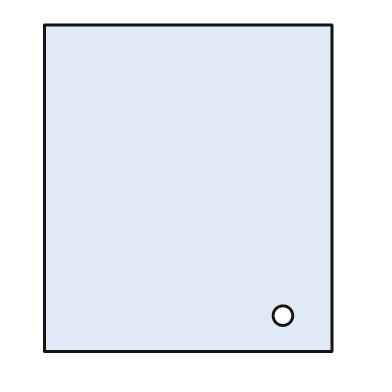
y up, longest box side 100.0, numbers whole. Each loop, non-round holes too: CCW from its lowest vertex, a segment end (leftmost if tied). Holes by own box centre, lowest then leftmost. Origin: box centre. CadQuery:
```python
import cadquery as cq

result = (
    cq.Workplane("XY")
    .moveTo(-44.0, -50.0)
    .lineTo(44.0, -50.0)
    .lineTo(44.0, 50.0)
    .lineTo(-44.0, 50.0)
    .close()
    .moveTo(29.0, -39.0)
    .circle(3.0)
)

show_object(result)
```